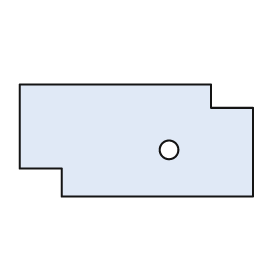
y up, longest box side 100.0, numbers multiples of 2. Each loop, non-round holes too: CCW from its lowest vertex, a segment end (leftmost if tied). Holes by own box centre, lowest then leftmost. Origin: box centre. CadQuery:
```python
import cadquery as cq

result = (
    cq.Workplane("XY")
    .moveTo(-32.0, -24.0)
    .lineTo(50.0, -24.0)
    .lineTo(50.0, 14.0)
    .lineTo(32.0, 14.0)
    .lineTo(32.0, 24.0)
    .lineTo(-50.0, 24.0)
    .lineTo(-50.0, -12.0)
    .lineTo(-32.0, -12.0)
    .close()
    .moveTo(14.0, -4.0)
    .circle(4.0)
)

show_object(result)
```